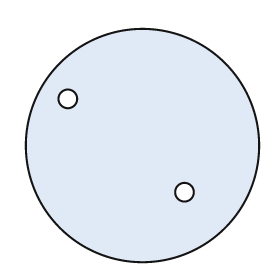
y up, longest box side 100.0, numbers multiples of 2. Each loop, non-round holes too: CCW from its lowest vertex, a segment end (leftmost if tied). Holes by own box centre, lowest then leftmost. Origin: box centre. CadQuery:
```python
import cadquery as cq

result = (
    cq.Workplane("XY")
    .moveTo(0.0, 0.0)
    .circle(50.0)
    .moveTo(18.0, -20.0)
    .circle(4.0)
    .moveTo(-32.0, 20.0)
    .circle(4.0)
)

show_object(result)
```